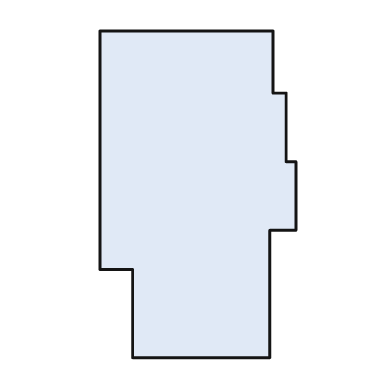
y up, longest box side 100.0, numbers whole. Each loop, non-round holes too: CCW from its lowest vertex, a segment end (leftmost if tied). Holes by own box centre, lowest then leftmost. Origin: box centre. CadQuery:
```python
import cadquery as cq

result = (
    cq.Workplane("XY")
    .moveTo(-20.0, -50.0)
    .lineTo(22.0, -50.0)
    .lineTo(22.0, -11.0)
    .lineTo(30.0, -11.0)
    .lineTo(30.0, 10.0)
    .lineTo(27.0, 10.0)
    .lineTo(27.0, 31.0)
    .lineTo(23.0, 31.0)
    .lineTo(23.0, 50.0)
    .lineTo(-30.0, 50.0)
    .lineTo(-30.0, -23.0)
    .lineTo(-20.0, -23.0)
    .close()
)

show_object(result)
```